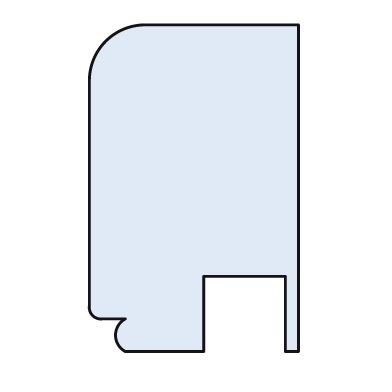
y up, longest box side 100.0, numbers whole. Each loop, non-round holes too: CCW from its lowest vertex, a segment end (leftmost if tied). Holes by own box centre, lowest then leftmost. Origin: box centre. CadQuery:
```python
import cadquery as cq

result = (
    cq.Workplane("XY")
    .moveTo(-21.0, -50.0)
    .lineTo(3.0, -50.0)
    .lineTo(3.0, -27.0)
    .lineTo(28.0, -27.0)
    .lineTo(28.0, -50.0)
    .lineTo(32.0, -50.0)
    .lineTo(32.0, 50.0)
    .lineTo(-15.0, 50.0)
    .threePointArc((-27.0, 45.0), (-32.0, 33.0))
    .lineTo(-32.0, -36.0)
    .threePointArc((-31.0, -39.0), (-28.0, -40.0))
    .lineTo(-21.0, -40.0)
    .threePointArc((-24.0, -45.0), (-21.0, -50.0))
    .close()
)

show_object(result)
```